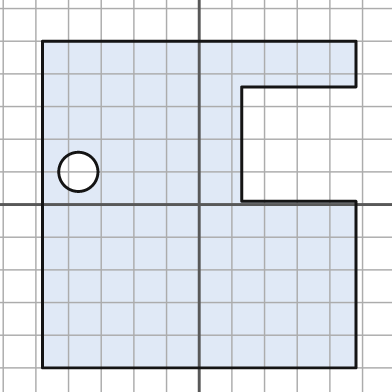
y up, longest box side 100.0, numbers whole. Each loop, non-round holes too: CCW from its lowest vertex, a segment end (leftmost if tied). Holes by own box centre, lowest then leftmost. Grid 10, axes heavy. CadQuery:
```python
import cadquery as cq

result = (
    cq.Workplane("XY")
    .moveTo(-48.0, -50.0)
    .lineTo(48.0, -50.0)
    .lineTo(48.0, 1.0)
    .lineTo(13.0, 1.0)
    .lineTo(13.0, 36.0)
    .lineTo(48.0, 36.0)
    .lineTo(48.0, 50.0)
    .lineTo(-48.0, 50.0)
    .close()
    .moveTo(-37.0, 10.0)
    .circle(6.0)
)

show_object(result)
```